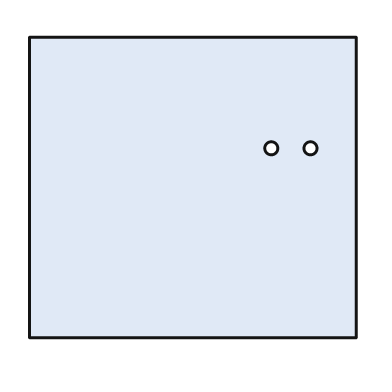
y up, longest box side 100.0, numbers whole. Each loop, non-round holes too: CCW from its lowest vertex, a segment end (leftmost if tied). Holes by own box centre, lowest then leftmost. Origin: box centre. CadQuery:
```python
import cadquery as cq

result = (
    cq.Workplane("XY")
    .moveTo(-50.0, -46.0)
    .lineTo(50.0, -46.0)
    .lineTo(50.0, 46.0)
    .lineTo(-50.0, 46.0)
    .close()
    .moveTo(24.0, 12.0)
    .circle(2.0)
    .moveTo(36.0, 12.0)
    .circle(2.0)
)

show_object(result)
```